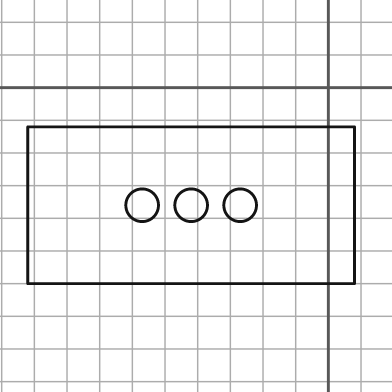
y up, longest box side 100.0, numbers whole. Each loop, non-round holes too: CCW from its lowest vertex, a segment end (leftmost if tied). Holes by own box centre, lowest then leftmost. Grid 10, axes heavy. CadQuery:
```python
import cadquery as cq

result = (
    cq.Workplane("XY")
    .moveTo(-92.0, -60.0)
    .lineTo(8.0, -60.0)
    .lineTo(8.0, -12.0)
    .lineTo(-92.0, -12.0)
    .close()
    .moveTo(-57.0, -36.0)
    .circle(5.0)
    .moveTo(-42.0, -36.0)
    .circle(5.0)
    .moveTo(-27.0, -36.0)
    .circle(5.0)
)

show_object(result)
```